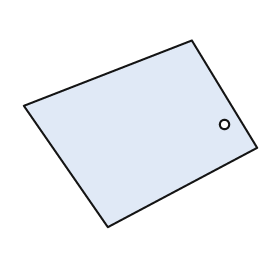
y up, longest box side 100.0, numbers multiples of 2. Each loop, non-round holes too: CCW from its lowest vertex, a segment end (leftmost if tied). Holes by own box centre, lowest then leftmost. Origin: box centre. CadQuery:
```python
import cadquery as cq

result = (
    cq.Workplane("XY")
    .moveTo(-14.0, -40.0)
    .lineTo(50.0, -6.0)
    .lineTo(22.0, 40.0)
    .lineTo(-50.0, 12.0)
    .close()
    .moveTo(36.0, 4.0)
    .circle(2.0)
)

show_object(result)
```